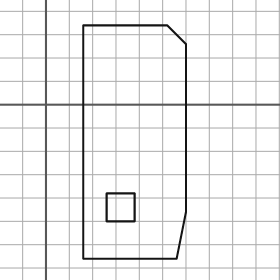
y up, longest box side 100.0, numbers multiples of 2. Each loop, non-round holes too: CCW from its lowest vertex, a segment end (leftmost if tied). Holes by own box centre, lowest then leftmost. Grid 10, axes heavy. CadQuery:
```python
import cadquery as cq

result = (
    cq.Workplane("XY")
    .moveTo(16.0, -66.0)
    .lineTo(56.0, -66.0)
    .lineTo(60.0, -46.0)
    .lineTo(60.0, 26.0)
    .lineTo(52.0, 34.0)
    .lineTo(16.0, 34.0)
    .close()
    .moveTo(26.0, -50.0)
    .lineTo(38.0, -50.0)
    .lineTo(38.0, -38.0)
    .lineTo(26.0, -38.0)
    .close()
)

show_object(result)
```